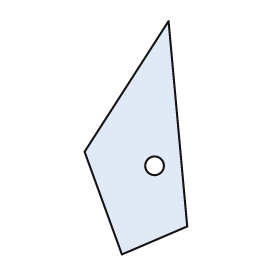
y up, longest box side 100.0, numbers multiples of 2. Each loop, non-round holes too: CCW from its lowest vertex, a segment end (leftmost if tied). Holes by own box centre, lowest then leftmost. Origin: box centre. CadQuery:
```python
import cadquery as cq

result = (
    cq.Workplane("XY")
    .moveTo(-6.0, -50.0)
    .lineTo(22.0, -38.0)
    .lineTo(14.0, 50.0)
    .lineTo(-22.0, -6.0)
    .close()
    .moveTo(8.0, -12.0)
    .circle(4.0)
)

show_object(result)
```